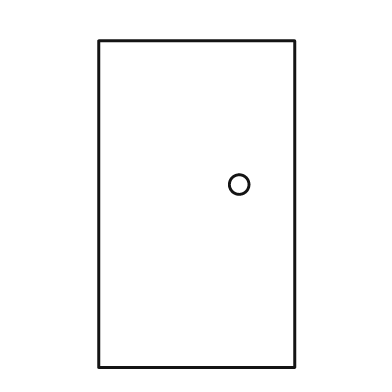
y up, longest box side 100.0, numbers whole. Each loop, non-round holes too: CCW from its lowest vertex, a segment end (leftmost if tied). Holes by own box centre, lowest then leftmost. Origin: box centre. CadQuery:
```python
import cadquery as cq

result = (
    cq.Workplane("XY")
    .moveTo(-30.0, -50.0)
    .lineTo(30.0, -50.0)
    .lineTo(30.0, 50.0)
    .lineTo(-30.0, 50.0)
    .close()
    .moveTo(13.0, 6.0)
    .circle(3.0)
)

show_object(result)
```